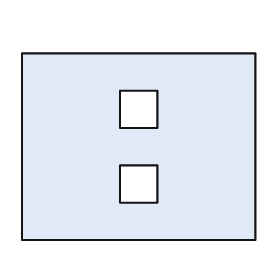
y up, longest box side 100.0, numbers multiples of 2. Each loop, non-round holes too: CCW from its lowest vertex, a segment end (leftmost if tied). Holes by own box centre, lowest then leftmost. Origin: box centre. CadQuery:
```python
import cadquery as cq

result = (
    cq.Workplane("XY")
    .moveTo(-50.0, -40.0)
    .lineTo(50.0, -40.0)
    .lineTo(50.0, 40.0)
    .lineTo(-50.0, 40.0)
    .close()
    .moveTo(-8.0, -24.0)
    .lineTo(8.0, -24.0)
    .lineTo(8.0, -8.0)
    .lineTo(-8.0, -8.0)
    .close()
    .moveTo(-8.0, 8.0)
    .lineTo(8.0, 8.0)
    .lineTo(8.0, 24.0)
    .lineTo(-8.0, 24.0)
    .close()
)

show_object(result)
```